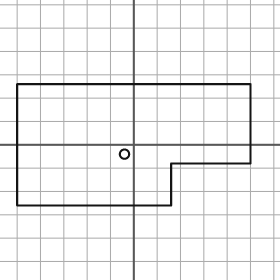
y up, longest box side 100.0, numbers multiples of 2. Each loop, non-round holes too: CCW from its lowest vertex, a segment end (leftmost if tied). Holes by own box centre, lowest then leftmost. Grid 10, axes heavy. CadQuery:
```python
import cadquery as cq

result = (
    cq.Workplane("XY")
    .moveTo(-50.0, -26.0)
    .lineTo(16.0, -26.0)
    .lineTo(16.0, -8.0)
    .lineTo(50.0, -8.0)
    .lineTo(50.0, 26.0)
    .lineTo(-50.0, 26.0)
    .close()
    .moveTo(-4.0, -4.0)
    .circle(2.0)
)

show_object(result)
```